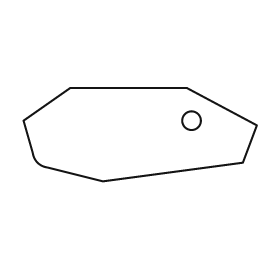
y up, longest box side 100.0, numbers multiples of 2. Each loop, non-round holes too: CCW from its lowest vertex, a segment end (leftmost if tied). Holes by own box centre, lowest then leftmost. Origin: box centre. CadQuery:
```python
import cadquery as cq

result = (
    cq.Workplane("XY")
    .moveTo(-16.0, -20.0)
    .lineTo(44.0, -12.0)
    .lineTo(50.0, 4.0)
    .lineTo(20.0, 20.0)
    .lineTo(-30.0, 20.0)
    .lineTo(-50.0, 6.0)
    .lineTo(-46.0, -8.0)
    .threePointArc((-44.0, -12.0), (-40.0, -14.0))
    .close()
    .moveTo(22.0, 6.0)
    .circle(4.0)
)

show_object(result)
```